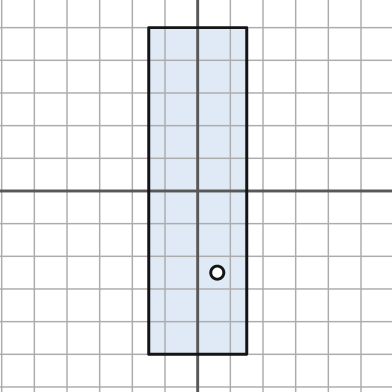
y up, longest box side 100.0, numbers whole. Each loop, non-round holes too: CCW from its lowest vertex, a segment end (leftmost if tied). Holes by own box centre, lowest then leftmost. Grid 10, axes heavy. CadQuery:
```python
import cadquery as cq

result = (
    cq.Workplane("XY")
    .moveTo(-15.0, -50.0)
    .lineTo(15.0, -50.0)
    .lineTo(15.0, 50.0)
    .lineTo(-15.0, 50.0)
    .close()
    .moveTo(6.0, -25.0)
    .circle(2.0)
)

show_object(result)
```